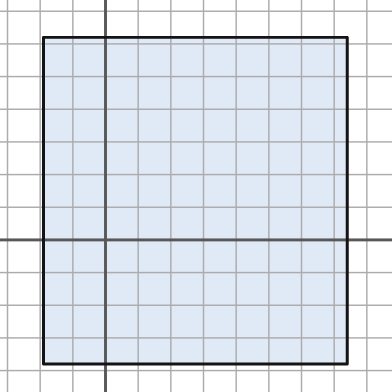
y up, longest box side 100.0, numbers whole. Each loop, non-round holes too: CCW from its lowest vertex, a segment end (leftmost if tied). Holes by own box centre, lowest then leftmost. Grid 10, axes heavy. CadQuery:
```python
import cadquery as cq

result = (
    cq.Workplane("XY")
    .moveTo(-19.0, -38.0)
    .lineTo(74.0, -38.0)
    .lineTo(74.0, 62.0)
    .lineTo(-19.0, 62.0)
    .close()
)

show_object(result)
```